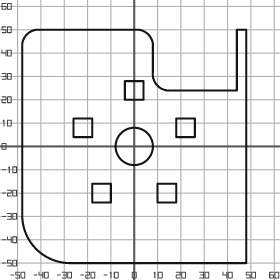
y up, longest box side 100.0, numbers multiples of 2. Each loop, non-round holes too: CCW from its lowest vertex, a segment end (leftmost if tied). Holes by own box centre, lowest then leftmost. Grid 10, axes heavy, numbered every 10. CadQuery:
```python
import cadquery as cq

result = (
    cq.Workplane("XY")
    .moveTo(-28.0, -50.0)
    .lineTo(48.0, -50.0)
    .lineTo(48.0, 50.0)
    .lineTo(44.0, 50.0)
    .lineTo(44.0, 24.0)
    .lineTo(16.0, 24.0)
    .threePointArc((10.0, 26.0), (8.0, 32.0))
    .lineTo(8.0, 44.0)
    .threePointArc((6.0, 48.0), (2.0, 50.0))
    .lineTo(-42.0, 50.0)
    .threePointArc((-46.0, 48.0), (-48.0, 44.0))
    .lineTo(-48.0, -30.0)
    .threePointArc((-42.0, -44.0), (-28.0, -50.0))
    .close()
    .moveTo(-18.0, -24.0)
    .lineTo(-10.0, -24.0)
    .lineTo(-10.0, -16.0)
    .lineTo(-18.0, -16.0)
    .close()
    .moveTo(10.0, -24.0)
    .lineTo(18.0, -24.0)
    .lineTo(18.0, -16.0)
    .lineTo(10.0, -16.0)
    .close()
    .moveTo(0.0, 0.0)
    .circle(8.0)
    .moveTo(-26.0, 4.0)
    .lineTo(-18.0, 4.0)
    .lineTo(-18.0, 12.0)
    .lineTo(-26.0, 12.0)
    .close()
    .moveTo(18.0, 4.0)
    .lineTo(26.0, 4.0)
    .lineTo(26.0, 12.0)
    .lineTo(18.0, 12.0)
    .close()
    .moveTo(-4.0, 20.0)
    .lineTo(4.0, 20.0)
    .lineTo(4.0, 28.0)
    .lineTo(-4.0, 28.0)
    .close()
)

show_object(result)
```